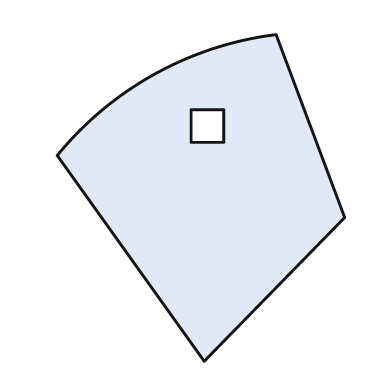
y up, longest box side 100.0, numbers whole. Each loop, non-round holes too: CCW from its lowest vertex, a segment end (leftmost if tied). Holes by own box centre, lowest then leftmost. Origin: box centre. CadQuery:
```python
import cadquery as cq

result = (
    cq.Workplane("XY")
    .moveTo(1.0, -50.0)
    .lineTo(44.0, -6.0)
    .lineTo(23.0, 50.0)
    .threePointArc((-14.0, 38.0), (-44.0, 13.0))
    .close()
    .moveTo(-3.0, 17.0)
    .lineTo(7.0, 17.0)
    .lineTo(7.0, 27.0)
    .lineTo(-3.0, 27.0)
    .close()
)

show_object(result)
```